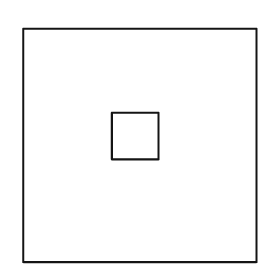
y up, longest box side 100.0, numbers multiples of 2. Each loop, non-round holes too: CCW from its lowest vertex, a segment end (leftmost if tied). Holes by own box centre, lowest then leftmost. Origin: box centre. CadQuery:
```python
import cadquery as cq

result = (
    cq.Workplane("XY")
    .moveTo(-50.0, -50.0)
    .lineTo(50.0, -50.0)
    .lineTo(50.0, 50.0)
    .lineTo(-50.0, 50.0)
    .close()
    .moveTo(-12.0, -6.0)
    .lineTo(8.0, -6.0)
    .lineTo(8.0, 14.0)
    .lineTo(-12.0, 14.0)
    .close()
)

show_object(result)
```